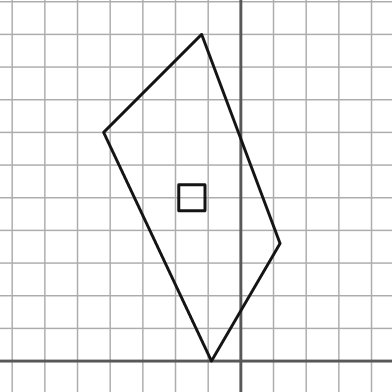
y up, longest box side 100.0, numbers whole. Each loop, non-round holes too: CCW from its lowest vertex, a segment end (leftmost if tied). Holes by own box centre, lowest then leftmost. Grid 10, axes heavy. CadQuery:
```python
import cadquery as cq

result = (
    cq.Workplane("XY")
    .moveTo(-9.0, 0.0)
    .lineTo(12.0, 36.0)
    .lineTo(-12.0, 100.0)
    .lineTo(-42.0, 70.0)
    .close()
    .moveTo(-19.0, 46.0)
    .lineTo(-11.0, 46.0)
    .lineTo(-11.0, 54.0)
    .lineTo(-19.0, 54.0)
    .close()
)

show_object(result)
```